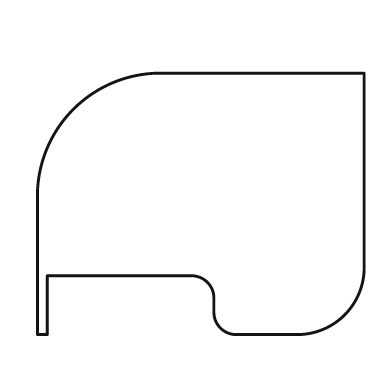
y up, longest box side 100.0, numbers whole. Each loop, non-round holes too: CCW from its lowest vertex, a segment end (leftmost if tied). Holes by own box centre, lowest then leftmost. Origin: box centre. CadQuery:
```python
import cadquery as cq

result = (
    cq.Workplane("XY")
    .moveTo(-50.0, -40.0)
    .lineTo(-47.0, -40.0)
    .lineTo(-47.0, -22.0)
    .lineTo(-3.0, -22.0)
    .threePointArc((2.0, -24.0), (4.0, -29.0))
    .lineTo(4.0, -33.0)
    .threePointArc((6.0, -38.0), (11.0, -40.0))
    .lineTo(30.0, -40.0)
    .threePointArc((44.0, -34.0), (50.0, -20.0))
    .lineTo(50.0, 40.0)
    .lineTo(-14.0, 40.0)
    .threePointArc((-39.0, 29.0), (-50.0, 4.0))
    .close()
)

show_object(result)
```